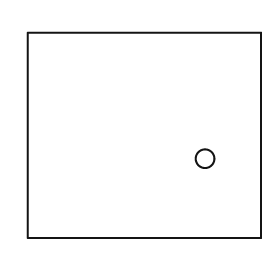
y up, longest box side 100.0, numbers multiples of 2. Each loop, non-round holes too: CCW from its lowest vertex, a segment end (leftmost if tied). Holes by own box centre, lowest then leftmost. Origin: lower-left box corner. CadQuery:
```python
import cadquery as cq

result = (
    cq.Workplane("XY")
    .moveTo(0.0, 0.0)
    .lineTo(100.0, 0.0)
    .lineTo(100.0, 88.0)
    .lineTo(0.0, 88.0)
    .close()
    .moveTo(76.0, 34.0)
    .circle(4.0)
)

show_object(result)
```